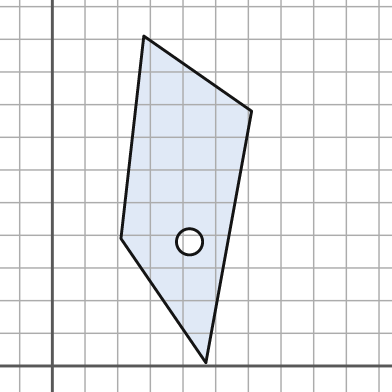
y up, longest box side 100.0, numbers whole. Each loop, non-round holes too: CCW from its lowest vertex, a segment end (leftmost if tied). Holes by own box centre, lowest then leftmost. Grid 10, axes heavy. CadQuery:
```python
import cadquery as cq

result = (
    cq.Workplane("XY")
    .moveTo(47.0, 1.0)
    .lineTo(61.0, 78.0)
    .lineTo(28.0, 101.0)
    .lineTo(21.0, 39.0)
    .close()
    .moveTo(42.0, 38.0)
    .circle(4.0)
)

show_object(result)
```